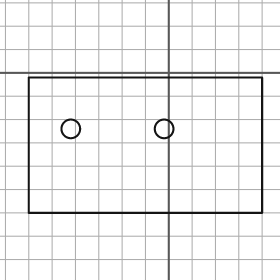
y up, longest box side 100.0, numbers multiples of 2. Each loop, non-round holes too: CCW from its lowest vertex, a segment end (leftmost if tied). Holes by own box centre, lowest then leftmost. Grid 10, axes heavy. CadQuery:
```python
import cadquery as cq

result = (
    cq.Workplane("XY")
    .moveTo(-60.0, -60.0)
    .lineTo(40.0, -60.0)
    .lineTo(40.0, -2.0)
    .lineTo(-60.0, -2.0)
    .close()
    .moveTo(-42.0, -24.0)
    .circle(4.0)
    .moveTo(-2.0, -24.0)
    .circle(4.0)
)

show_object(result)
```